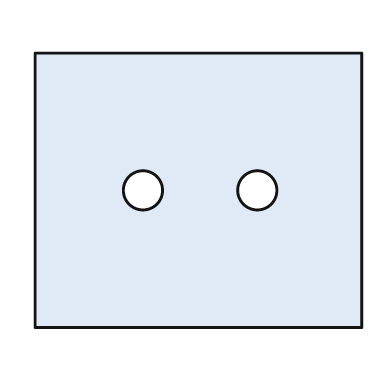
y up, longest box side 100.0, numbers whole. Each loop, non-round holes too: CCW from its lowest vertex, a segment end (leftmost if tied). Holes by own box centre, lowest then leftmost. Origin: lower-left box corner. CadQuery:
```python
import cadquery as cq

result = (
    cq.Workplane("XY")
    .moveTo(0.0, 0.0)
    .lineTo(100.0, 0.0)
    .lineTo(100.0, 84.0)
    .lineTo(0.0, 84.0)
    .close()
    .moveTo(33.0, 42.0)
    .circle(6.0)
    .moveTo(68.0, 42.0)
    .circle(6.0)
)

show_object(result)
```